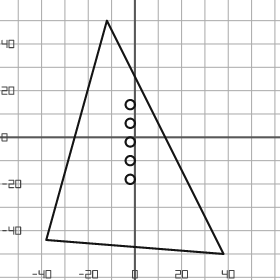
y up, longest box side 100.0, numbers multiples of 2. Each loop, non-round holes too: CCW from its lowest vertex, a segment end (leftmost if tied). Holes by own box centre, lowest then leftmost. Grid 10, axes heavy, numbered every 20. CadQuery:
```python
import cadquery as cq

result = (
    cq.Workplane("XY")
    .moveTo(38.0, -50.0)
    .lineTo(-12.0, 50.0)
    .lineTo(-38.0, -44.0)
    .close()
    .moveTo(-2.0, -18.0)
    .circle(2.0)
    .moveTo(-2.0, -10.0)
    .circle(2.0)
    .moveTo(-2.0, -2.0)
    .circle(2.0)
    .moveTo(-2.0, 6.0)
    .circle(2.0)
    .moveTo(-2.0, 14.0)
    .circle(2.0)
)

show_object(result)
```